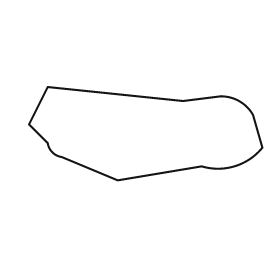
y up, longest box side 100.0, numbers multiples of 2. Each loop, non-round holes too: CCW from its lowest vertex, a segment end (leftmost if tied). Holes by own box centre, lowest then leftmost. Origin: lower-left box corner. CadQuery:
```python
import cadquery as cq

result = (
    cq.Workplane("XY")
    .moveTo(38.0, 0.0)
    .lineTo(74.0, 6.0)
    .threePointArc((88.0, 6.0), (100.0, 14.0))
    .lineTo(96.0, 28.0)
    .threePointArc((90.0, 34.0), (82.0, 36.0))
    .lineTo(66.0, 34.0)
    .lineTo(8.0, 40.0)
    .lineTo(0.0, 24.0)
    .lineTo(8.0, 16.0)
    .threePointArc((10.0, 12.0), (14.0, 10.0))
    .close()
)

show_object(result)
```